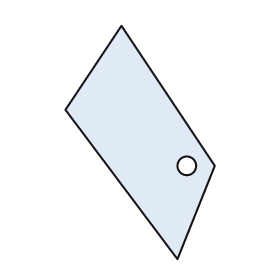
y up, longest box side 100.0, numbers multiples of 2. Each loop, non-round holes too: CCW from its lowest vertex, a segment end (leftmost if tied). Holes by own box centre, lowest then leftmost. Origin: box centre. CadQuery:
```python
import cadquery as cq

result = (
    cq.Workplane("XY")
    .moveTo(16.0, -50.0)
    .lineTo(32.0, -10.0)
    .lineTo(-8.0, 50.0)
    .lineTo(-32.0, 14.0)
    .close()
    .moveTo(20.0, -10.0)
    .circle(4.0)
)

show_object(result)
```